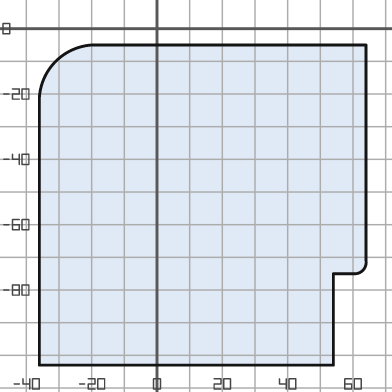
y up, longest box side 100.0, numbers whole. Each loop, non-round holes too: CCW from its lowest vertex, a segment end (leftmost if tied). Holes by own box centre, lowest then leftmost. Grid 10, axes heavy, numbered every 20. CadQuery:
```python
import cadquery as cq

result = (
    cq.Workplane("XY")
    .moveTo(-36.0, -103.0)
    .lineTo(54.0, -103.0)
    .lineTo(54.0, -75.0)
    .lineTo(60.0, -75.0)
    .threePointArc((63.0, -74.0), (64.0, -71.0))
    .lineTo(64.0, -5.0)
    .lineTo(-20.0, -5.0)
    .threePointArc((-31.0, -10.0), (-36.0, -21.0))
    .close()
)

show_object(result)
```